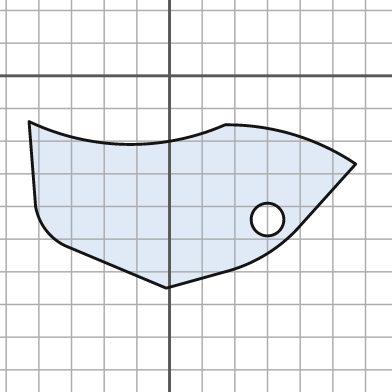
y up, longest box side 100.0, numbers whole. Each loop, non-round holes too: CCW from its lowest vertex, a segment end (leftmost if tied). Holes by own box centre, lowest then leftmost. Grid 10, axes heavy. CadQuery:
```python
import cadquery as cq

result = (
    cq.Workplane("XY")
    .moveTo(-1.0, -65.0)
    .lineTo(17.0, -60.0)
    .threePointArc((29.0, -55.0), (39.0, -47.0))
    .lineTo(57.0, -27.0)
    .threePointArc((38.0, -18.0), (17.0, -15.0))
    .threePointArc((-13.0, -21.0), (-43.0, -14.0))
    .lineTo(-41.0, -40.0)
    .threePointArc((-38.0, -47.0), (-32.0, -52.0))
    .close()
    .moveTo(30.0, -44.0)
    .circle(5.0)
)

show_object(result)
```